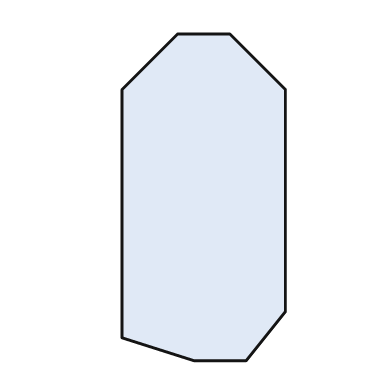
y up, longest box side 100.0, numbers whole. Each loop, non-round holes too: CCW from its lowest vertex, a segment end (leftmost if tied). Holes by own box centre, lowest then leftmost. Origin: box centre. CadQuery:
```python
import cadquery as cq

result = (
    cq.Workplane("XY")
    .moveTo(-3.0, -50.0)
    .lineTo(13.0, -50.0)
    .lineTo(25.0, -35.0)
    .lineTo(25.0, 33.0)
    .lineTo(8.0, 50.0)
    .lineTo(-8.0, 50.0)
    .lineTo(-25.0, 33.0)
    .lineTo(-25.0, -43.0)
    .close()
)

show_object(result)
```